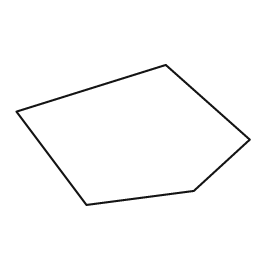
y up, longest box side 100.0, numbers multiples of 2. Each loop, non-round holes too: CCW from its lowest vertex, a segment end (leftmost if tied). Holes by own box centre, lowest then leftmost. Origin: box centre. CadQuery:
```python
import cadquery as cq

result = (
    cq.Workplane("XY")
    .moveTo(-20.0, -30.0)
    .lineTo(26.0, -24.0)
    .lineTo(50.0, -2.0)
    .lineTo(14.0, 30.0)
    .lineTo(-50.0, 10.0)
    .close()
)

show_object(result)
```